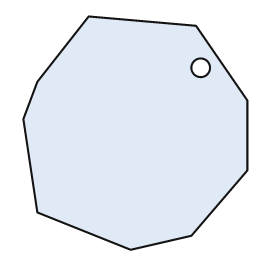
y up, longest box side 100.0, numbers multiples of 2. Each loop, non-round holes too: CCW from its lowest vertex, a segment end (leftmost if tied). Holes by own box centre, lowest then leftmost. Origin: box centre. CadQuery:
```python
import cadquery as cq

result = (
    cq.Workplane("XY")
    .moveTo(-2.0, -50.0)
    .lineTo(24.0, -44.0)
    .lineTo(48.0, -16.0)
    .lineTo(48.0, 14.0)
    .lineTo(26.0, 46.0)
    .lineTo(-20.0, 50.0)
    .lineTo(-42.0, 22.0)
    .lineTo(-48.0, 6.0)
    .lineTo(-42.0, -34.0)
    .close()
    .moveTo(28.0, 28.0)
    .circle(4.0)
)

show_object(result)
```